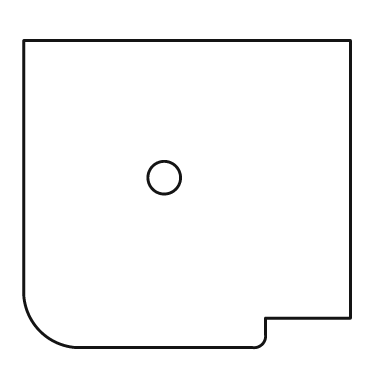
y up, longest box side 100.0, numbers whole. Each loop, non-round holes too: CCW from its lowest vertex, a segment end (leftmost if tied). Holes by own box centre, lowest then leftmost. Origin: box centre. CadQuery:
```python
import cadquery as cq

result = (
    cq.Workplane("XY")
    .moveTo(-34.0, -47.0)
    .lineTo(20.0, -47.0)
    .threePointArc((23.0, -46.0), (24.0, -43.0))
    .lineTo(24.0, -38.0)
    .lineTo(50.0, -38.0)
    .lineTo(50.0, 47.0)
    .lineTo(-50.0, 47.0)
    .lineTo(-50.0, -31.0)
    .threePointArc((-45.0, -42.0), (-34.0, -47.0))
    .close()
    .moveTo(-7.0, 5.0)
    .circle(5.0)
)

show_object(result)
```